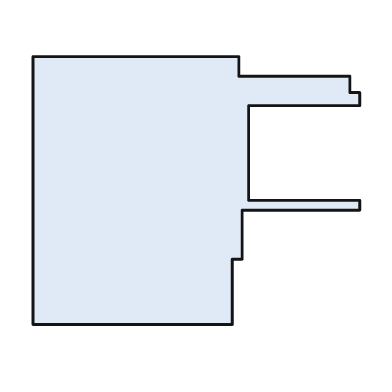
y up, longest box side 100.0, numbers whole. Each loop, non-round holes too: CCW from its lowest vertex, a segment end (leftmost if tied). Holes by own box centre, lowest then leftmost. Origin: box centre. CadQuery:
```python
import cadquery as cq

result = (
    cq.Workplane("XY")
    .moveTo(-50.0, -41.0)
    .lineTo(11.0, -41.0)
    .lineTo(11.0, -21.0)
    .lineTo(14.0, -21.0)
    .lineTo(14.0, -6.0)
    .lineTo(50.0, -6.0)
    .lineTo(50.0, -3.0)
    .lineTo(16.0, -3.0)
    .lineTo(16.0, 26.0)
    .lineTo(50.0, 26.0)
    .lineTo(50.0, 30.0)
    .lineTo(47.0, 30.0)
    .lineTo(47.0, 35.0)
    .lineTo(13.0, 35.0)
    .lineTo(13.0, 41.0)
    .lineTo(-50.0, 41.0)
    .close()
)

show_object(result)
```